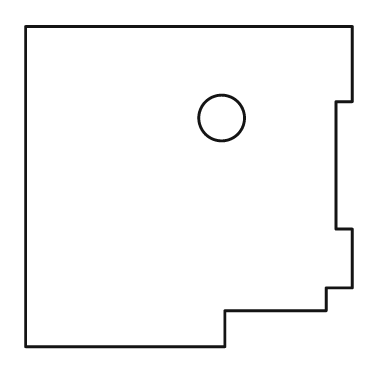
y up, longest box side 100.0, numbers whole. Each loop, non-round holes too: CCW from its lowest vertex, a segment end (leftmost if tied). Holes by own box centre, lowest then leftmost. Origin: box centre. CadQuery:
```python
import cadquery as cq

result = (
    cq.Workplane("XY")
    .moveTo(-50.0, -49.0)
    .lineTo(11.0, -49.0)
    .lineTo(11.0, -38.0)
    .lineTo(42.0, -38.0)
    .lineTo(42.0, -31.0)
    .lineTo(50.0, -31.0)
    .lineTo(50.0, -13.0)
    .lineTo(45.0, -13.0)
    .lineTo(45.0, 26.0)
    .lineTo(50.0, 26.0)
    .lineTo(50.0, 49.0)
    .lineTo(-50.0, 49.0)
    .close()
    .moveTo(10.0, 21.0)
    .circle(7.0)
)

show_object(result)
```